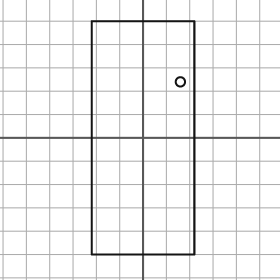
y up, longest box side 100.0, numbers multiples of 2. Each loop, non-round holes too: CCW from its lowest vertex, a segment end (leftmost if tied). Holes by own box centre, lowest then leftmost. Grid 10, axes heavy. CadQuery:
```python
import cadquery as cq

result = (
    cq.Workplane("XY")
    .moveTo(-22.0, -50.0)
    .lineTo(22.0, -50.0)
    .lineTo(22.0, 50.0)
    .lineTo(-22.0, 50.0)
    .close()
    .moveTo(16.0, 24.0)
    .circle(2.0)
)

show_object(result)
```